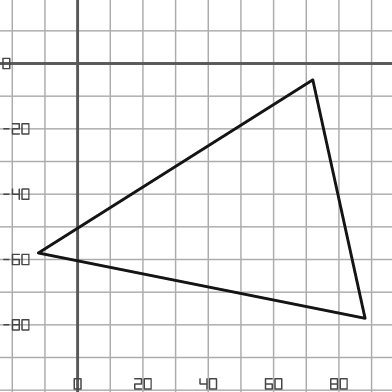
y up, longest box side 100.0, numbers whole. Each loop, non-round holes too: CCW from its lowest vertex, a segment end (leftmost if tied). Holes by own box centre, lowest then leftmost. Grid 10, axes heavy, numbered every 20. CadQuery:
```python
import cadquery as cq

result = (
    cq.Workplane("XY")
    .moveTo(88.0, -78.0)
    .lineTo(72.0, -5.0)
    .lineTo(-12.0, -58.0)
    .close()
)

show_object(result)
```